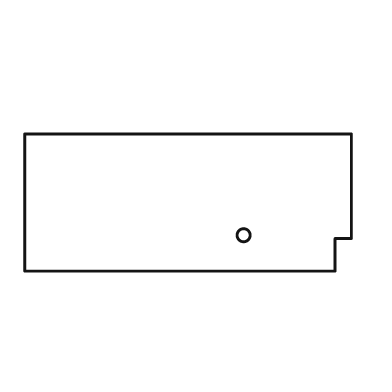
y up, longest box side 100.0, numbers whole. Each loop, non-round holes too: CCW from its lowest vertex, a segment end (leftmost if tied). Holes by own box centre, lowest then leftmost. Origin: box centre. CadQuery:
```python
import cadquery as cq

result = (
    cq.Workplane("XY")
    .moveTo(-50.0, -21.0)
    .lineTo(45.0, -21.0)
    .lineTo(45.0, -11.0)
    .lineTo(50.0, -11.0)
    .lineTo(50.0, 21.0)
    .lineTo(-50.0, 21.0)
    .close()
    .moveTo(17.0, -10.0)
    .circle(2.0)
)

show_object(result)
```